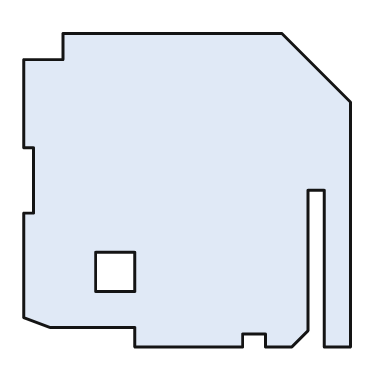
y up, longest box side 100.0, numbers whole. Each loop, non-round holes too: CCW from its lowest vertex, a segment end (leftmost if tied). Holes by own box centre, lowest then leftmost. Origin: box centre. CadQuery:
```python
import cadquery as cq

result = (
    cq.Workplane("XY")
    .moveTo(-16.0, -48.0)
    .lineTo(17.0, -48.0)
    .lineTo(17.0, -44.0)
    .lineTo(24.0, -44.0)
    .lineTo(24.0, -48.0)
    .lineTo(32.0, -48.0)
    .lineTo(37.0, -43.0)
    .lineTo(37.0, 0.0)
    .lineTo(42.0, 0.0)
    .lineTo(42.0, -48.0)
    .lineTo(50.0, -48.0)
    .lineTo(50.0, 27.0)
    .lineTo(29.0, 48.0)
    .lineTo(-38.0, 48.0)
    .lineTo(-38.0, 40.0)
    .lineTo(-50.0, 40.0)
    .lineTo(-50.0, 13.0)
    .lineTo(-47.0, 13.0)
    .lineTo(-47.0, -7.0)
    .lineTo(-50.0, -7.0)
    .lineTo(-50.0, -39.0)
    .lineTo(-42.0, -42.0)
    .lineTo(-16.0, -42.0)
    .close()
    .moveTo(-28.0, -31.0)
    .lineTo(-16.0, -31.0)
    .lineTo(-16.0, -19.0)
    .lineTo(-28.0, -19.0)
    .close()
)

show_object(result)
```